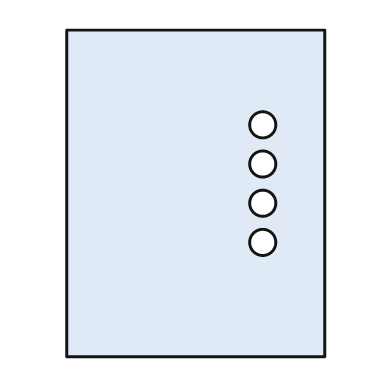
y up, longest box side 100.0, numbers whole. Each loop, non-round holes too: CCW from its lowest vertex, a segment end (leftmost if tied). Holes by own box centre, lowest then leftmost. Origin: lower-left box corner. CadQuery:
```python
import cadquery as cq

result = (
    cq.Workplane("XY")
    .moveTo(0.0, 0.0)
    .lineTo(79.0, 0.0)
    .lineTo(79.0, 100.0)
    .lineTo(0.0, 100.0)
    .close()
    .moveTo(60.0, 35.0)
    .circle(4.0)
    .moveTo(60.0, 47.0)
    .circle(4.0)
    .moveTo(60.0, 59.0)
    .circle(4.0)
    .moveTo(60.0, 71.0)
    .circle(4.0)
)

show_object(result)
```